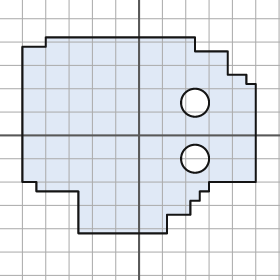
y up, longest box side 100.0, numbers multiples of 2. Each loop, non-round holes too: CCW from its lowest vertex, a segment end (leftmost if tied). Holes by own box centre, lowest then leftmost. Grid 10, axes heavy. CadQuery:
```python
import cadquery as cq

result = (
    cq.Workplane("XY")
    .moveTo(-26.0, -42.0)
    .lineTo(12.0, -42.0)
    .lineTo(12.0, -34.0)
    .lineTo(22.0, -34.0)
    .lineTo(22.0, -28.0)
    .lineTo(26.0, -28.0)
    .lineTo(26.0, -24.0)
    .lineTo(30.0, -24.0)
    .lineTo(30.0, -20.0)
    .lineTo(50.0, -20.0)
    .lineTo(50.0, 22.0)
    .lineTo(46.0, 22.0)
    .lineTo(46.0, 26.0)
    .lineTo(38.0, 26.0)
    .lineTo(38.0, 36.0)
    .lineTo(24.0, 36.0)
    .lineTo(24.0, 42.0)
    .lineTo(-40.0, 42.0)
    .lineTo(-40.0, 38.0)
    .lineTo(-50.0, 38.0)
    .lineTo(-50.0, -20.0)
    .lineTo(-44.0, -20.0)
    .lineTo(-44.0, -24.0)
    .lineTo(-26.0, -24.0)
    .close()
    .moveTo(24.0, -10.0)
    .circle(6.0)
    .moveTo(24.0, 14.0)
    .circle(6.0)
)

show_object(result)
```